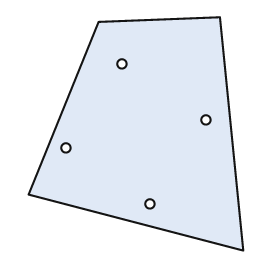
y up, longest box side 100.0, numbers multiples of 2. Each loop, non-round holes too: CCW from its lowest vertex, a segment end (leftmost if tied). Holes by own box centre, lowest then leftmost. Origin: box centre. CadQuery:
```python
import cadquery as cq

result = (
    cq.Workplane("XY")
    .moveTo(46.0, -50.0)
    .lineTo(36.0, 50.0)
    .lineTo(-16.0, 48.0)
    .lineTo(-46.0, -26.0)
    .close()
    .moveTo(6.0, -30.0)
    .circle(2.0)
    .moveTo(-30.0, -6.0)
    .circle(2.0)
    .moveTo(30.0, 6.0)
    .circle(2.0)
    .moveTo(-6.0, 30.0)
    .circle(2.0)
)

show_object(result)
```